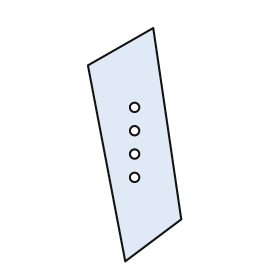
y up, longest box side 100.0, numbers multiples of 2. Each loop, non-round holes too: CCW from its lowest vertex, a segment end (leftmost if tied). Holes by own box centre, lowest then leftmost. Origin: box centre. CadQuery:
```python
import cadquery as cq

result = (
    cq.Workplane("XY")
    .moveTo(-4.0, -50.0)
    .lineTo(20.0, -32.0)
    .lineTo(8.0, 50.0)
    .lineTo(-20.0, 34.0)
    .close()
    .moveTo(0.0, -14.0)
    .circle(2.0)
    .moveTo(0.0, -4.0)
    .circle(2.0)
    .moveTo(0.0, 6.0)
    .circle(2.0)
    .moveTo(0.0, 16.0)
    .circle(2.0)
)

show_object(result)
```